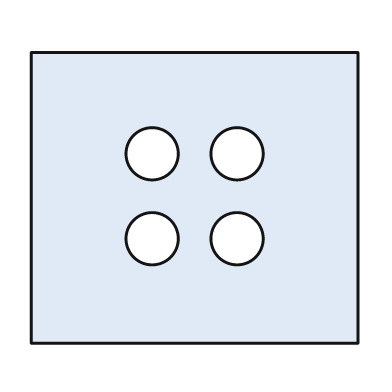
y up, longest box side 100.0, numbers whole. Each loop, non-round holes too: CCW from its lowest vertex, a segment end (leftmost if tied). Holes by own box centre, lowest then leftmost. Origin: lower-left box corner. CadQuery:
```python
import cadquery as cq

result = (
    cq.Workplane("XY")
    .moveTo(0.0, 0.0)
    .lineTo(100.0, 0.0)
    .lineTo(100.0, 89.0)
    .lineTo(0.0, 89.0)
    .close()
    .moveTo(37.0, 32.0)
    .circle(8.0)
    .moveTo(63.0, 32.0)
    .circle(8.0)
    .moveTo(37.0, 58.0)
    .circle(8.0)
    .moveTo(63.0, 58.0)
    .circle(8.0)
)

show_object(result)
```